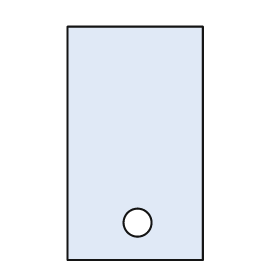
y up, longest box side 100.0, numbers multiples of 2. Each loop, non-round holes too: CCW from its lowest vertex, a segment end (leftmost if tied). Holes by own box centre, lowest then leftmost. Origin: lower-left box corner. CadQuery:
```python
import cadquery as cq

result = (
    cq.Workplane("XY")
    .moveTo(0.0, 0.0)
    .lineTo(58.0, 0.0)
    .lineTo(58.0, 100.0)
    .lineTo(0.0, 100.0)
    .close()
    .moveTo(30.0, 16.0)
    .circle(6.0)
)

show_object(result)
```